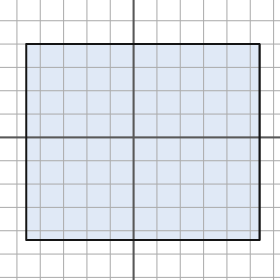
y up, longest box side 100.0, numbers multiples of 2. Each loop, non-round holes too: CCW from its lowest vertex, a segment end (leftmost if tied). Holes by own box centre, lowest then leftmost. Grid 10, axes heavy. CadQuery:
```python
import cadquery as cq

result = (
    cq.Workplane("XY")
    .moveTo(-46.0, -44.0)
    .lineTo(54.0, -44.0)
    .lineTo(54.0, 40.0)
    .lineTo(-46.0, 40.0)
    .close()
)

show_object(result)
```